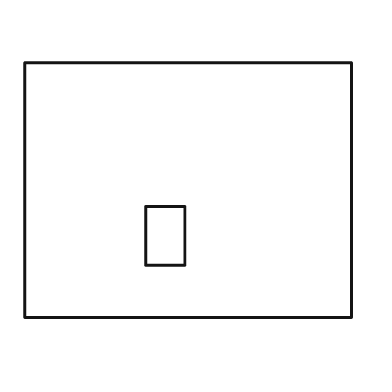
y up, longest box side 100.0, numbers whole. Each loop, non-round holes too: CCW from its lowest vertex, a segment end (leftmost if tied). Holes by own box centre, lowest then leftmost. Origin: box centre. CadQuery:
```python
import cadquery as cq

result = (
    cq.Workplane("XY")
    .moveTo(-50.0, -39.0)
    .lineTo(50.0, -39.0)
    .lineTo(50.0, 39.0)
    .lineTo(-50.0, 39.0)
    .close()
    .moveTo(-13.0, -23.0)
    .lineTo(-1.0, -23.0)
    .lineTo(-1.0, -5.0)
    .lineTo(-13.0, -5.0)
    .close()
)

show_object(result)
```